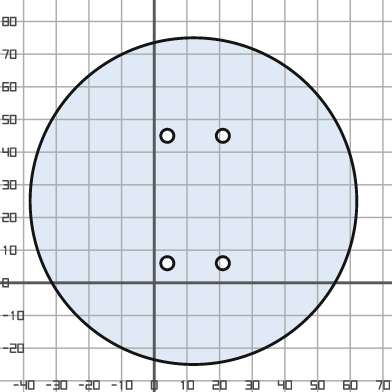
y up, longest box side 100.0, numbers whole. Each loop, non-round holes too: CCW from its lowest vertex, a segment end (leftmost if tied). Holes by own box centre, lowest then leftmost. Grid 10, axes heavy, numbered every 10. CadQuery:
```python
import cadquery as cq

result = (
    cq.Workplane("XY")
    .moveTo(12.0, 25.0)
    .circle(50.0)
    .moveTo(4.0, 6.0)
    .circle(2.0)
    .moveTo(21.0, 6.0)
    .circle(2.0)
    .moveTo(4.0, 45.0)
    .circle(2.0)
    .moveTo(21.0, 45.0)
    .circle(2.0)
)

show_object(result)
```